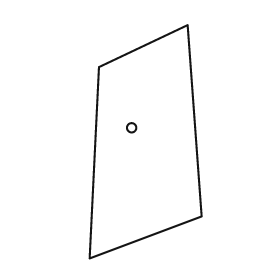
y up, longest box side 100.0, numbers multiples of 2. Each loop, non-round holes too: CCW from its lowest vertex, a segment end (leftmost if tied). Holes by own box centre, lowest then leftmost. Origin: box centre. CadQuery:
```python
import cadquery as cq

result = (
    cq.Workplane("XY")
    .moveTo(-24.0, -50.0)
    .lineTo(24.0, -32.0)
    .lineTo(18.0, 50.0)
    .lineTo(-20.0, 32.0)
    .close()
    .moveTo(-6.0, 6.0)
    .circle(2.0)
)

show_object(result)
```